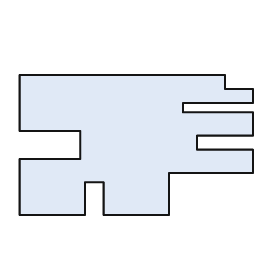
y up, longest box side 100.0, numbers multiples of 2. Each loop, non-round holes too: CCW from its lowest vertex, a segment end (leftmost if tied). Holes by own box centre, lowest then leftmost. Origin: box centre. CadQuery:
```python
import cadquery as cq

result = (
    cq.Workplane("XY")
    .moveTo(-50.0, -30.0)
    .lineTo(-22.0, -30.0)
    .lineTo(-22.0, -16.0)
    .lineTo(-14.0, -16.0)
    .lineTo(-14.0, -30.0)
    .lineTo(14.0, -30.0)
    .lineTo(14.0, -12.0)
    .lineTo(50.0, -12.0)
    .lineTo(50.0, -2.0)
    .lineTo(26.0, -2.0)
    .lineTo(26.0, 4.0)
    .lineTo(50.0, 4.0)
    .lineTo(50.0, 14.0)
    .lineTo(20.0, 14.0)
    .lineTo(20.0, 18.0)
    .lineTo(50.0, 18.0)
    .lineTo(50.0, 24.0)
    .lineTo(38.0, 24.0)
    .lineTo(38.0, 30.0)
    .lineTo(-50.0, 30.0)
    .lineTo(-50.0, 6.0)
    .lineTo(-24.0, 6.0)
    .lineTo(-24.0, -6.0)
    .lineTo(-50.0, -6.0)
    .close()
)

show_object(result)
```